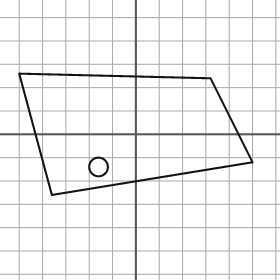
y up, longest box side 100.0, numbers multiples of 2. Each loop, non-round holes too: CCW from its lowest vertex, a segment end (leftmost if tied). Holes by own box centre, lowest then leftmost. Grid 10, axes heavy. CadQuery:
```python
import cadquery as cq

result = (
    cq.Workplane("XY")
    .moveTo(-36.0, -26.0)
    .lineTo(50.0, -12.0)
    .lineTo(32.0, 24.0)
    .lineTo(-50.0, 26.0)
    .close()
    .moveTo(-16.0, -14.0)
    .circle(4.0)
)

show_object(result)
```